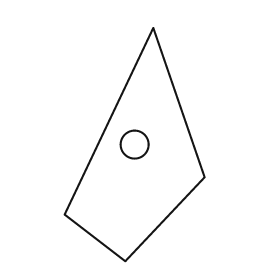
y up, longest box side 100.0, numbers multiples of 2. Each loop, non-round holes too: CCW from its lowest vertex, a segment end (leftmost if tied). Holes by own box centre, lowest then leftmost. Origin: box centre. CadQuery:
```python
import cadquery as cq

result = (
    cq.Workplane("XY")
    .moveTo(-4.0, -50.0)
    .lineTo(30.0, -14.0)
    .lineTo(8.0, 50.0)
    .lineTo(-30.0, -30.0)
    .close()
    .moveTo(0.0, 0.0)
    .circle(6.0)
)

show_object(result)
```